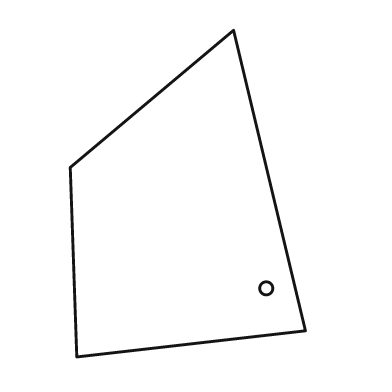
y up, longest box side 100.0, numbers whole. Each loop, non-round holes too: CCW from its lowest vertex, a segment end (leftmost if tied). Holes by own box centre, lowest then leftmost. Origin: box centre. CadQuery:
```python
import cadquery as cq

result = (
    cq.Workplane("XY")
    .moveTo(-34.0, -50.0)
    .lineTo(36.0, -42.0)
    .lineTo(14.0, 50.0)
    .lineTo(-36.0, 8.0)
    .close()
    .moveTo(24.0, -29.0)
    .circle(2.0)
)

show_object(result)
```